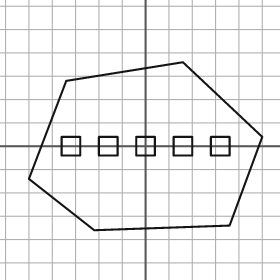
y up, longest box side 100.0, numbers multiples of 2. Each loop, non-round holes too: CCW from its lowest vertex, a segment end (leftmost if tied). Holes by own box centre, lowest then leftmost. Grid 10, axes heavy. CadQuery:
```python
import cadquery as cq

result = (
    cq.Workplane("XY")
    .moveTo(-22.0, -36.0)
    .lineTo(36.0, -34.0)
    .lineTo(50.0, 4.0)
    .lineTo(16.0, 36.0)
    .lineTo(-34.0, 28.0)
    .lineTo(-50.0, -14.0)
    .close()
    .moveTo(-36.0, -4.0)
    .lineTo(-28.0, -4.0)
    .lineTo(-28.0, 4.0)
    .lineTo(-36.0, 4.0)
    .close()
    .moveTo(-20.0, -4.0)
    .lineTo(-12.0, -4.0)
    .lineTo(-12.0, 4.0)
    .lineTo(-20.0, 4.0)
    .close()
    .moveTo(-4.0, -4.0)
    .lineTo(4.0, -4.0)
    .lineTo(4.0, 4.0)
    .lineTo(-4.0, 4.0)
    .close()
    .moveTo(12.0, -4.0)
    .lineTo(20.0, -4.0)
    .lineTo(20.0, 4.0)
    .lineTo(12.0, 4.0)
    .close()
    .moveTo(28.0, -4.0)
    .lineTo(36.0, -4.0)
    .lineTo(36.0, 4.0)
    .lineTo(28.0, 4.0)
    .close()
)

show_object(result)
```